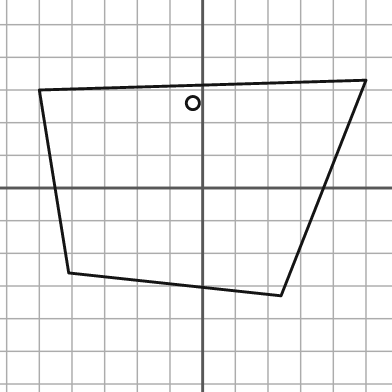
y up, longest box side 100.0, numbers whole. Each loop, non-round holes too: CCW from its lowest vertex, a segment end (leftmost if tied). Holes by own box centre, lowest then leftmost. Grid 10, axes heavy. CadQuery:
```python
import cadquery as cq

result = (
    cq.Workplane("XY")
    .moveTo(24.0, -33.0)
    .lineTo(50.0, 33.0)
    .lineTo(-50.0, 30.0)
    .lineTo(-41.0, -26.0)
    .close()
    .moveTo(-3.0, 26.0)
    .circle(2.0)
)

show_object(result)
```